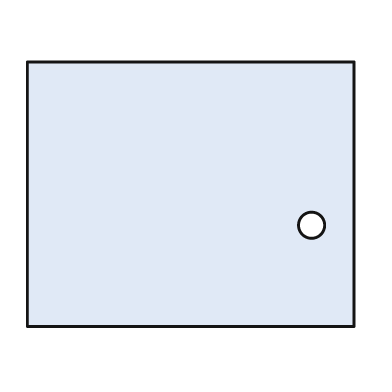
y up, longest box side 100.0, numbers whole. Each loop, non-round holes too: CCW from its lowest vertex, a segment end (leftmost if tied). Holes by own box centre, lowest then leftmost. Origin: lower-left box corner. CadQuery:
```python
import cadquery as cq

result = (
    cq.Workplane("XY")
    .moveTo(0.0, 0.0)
    .lineTo(100.0, 0.0)
    .lineTo(100.0, 81.0)
    .lineTo(0.0, 81.0)
    .close()
    .moveTo(87.0, 31.0)
    .circle(4.0)
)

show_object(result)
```